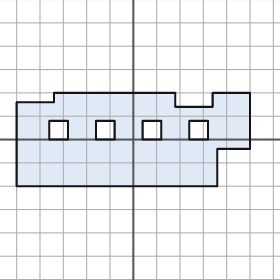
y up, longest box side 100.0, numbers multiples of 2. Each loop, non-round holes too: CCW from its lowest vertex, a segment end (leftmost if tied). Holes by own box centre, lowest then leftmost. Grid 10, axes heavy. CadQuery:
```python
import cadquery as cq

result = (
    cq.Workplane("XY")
    .moveTo(-50.0, -20.0)
    .lineTo(36.0, -20.0)
    .lineTo(36.0, -4.0)
    .lineTo(50.0, -4.0)
    .lineTo(50.0, 20.0)
    .lineTo(34.0, 20.0)
    .lineTo(34.0, 14.0)
    .lineTo(18.0, 14.0)
    .lineTo(18.0, 20.0)
    .lineTo(-34.0, 20.0)
    .lineTo(-34.0, 16.0)
    .lineTo(-50.0, 16.0)
    .close()
    .moveTo(-36.0, 0.0)
    .lineTo(-28.0, 0.0)
    .lineTo(-28.0, 8.0)
    .lineTo(-36.0, 8.0)
    .close()
    .moveTo(-16.0, 0.0)
    .lineTo(-8.0, 0.0)
    .lineTo(-8.0, 8.0)
    .lineTo(-16.0, 8.0)
    .close()
    .moveTo(4.0, 0.0)
    .lineTo(12.0, 0.0)
    .lineTo(12.0, 8.0)
    .lineTo(4.0, 8.0)
    .close()
    .moveTo(24.0, 0.0)
    .lineTo(32.0, 0.0)
    .lineTo(32.0, 8.0)
    .lineTo(24.0, 8.0)
    .close()
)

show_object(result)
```